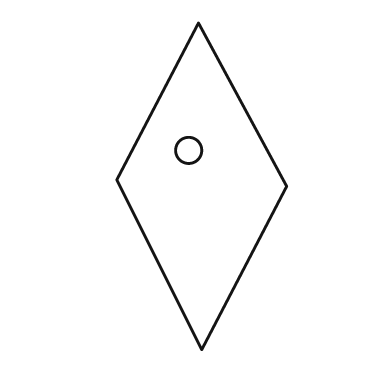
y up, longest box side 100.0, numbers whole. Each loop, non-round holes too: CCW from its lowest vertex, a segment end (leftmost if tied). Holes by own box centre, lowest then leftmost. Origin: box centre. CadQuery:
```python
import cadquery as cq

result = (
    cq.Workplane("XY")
    .moveTo(0.0, -50.0)
    .lineTo(26.0, 0.0)
    .lineTo(-1.0, 50.0)
    .lineTo(-26.0, 2.0)
    .close()
    .moveTo(-4.0, 11.0)
    .circle(4.0)
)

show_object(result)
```